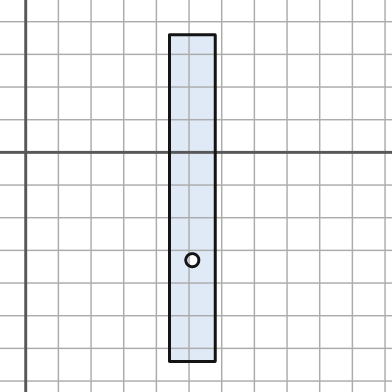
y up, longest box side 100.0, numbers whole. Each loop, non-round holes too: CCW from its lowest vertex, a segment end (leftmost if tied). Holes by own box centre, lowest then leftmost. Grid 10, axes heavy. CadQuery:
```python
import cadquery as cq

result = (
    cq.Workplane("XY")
    .moveTo(44.0, -64.0)
    .lineTo(58.0, -64.0)
    .lineTo(58.0, 36.0)
    .lineTo(44.0, 36.0)
    .close()
    .moveTo(51.0, -33.0)
    .circle(2.0)
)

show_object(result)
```